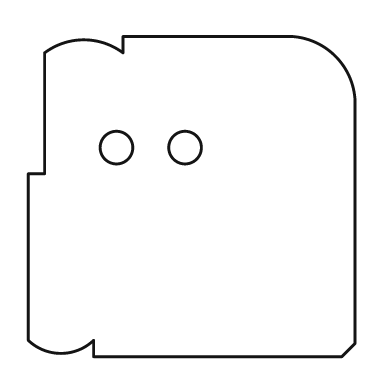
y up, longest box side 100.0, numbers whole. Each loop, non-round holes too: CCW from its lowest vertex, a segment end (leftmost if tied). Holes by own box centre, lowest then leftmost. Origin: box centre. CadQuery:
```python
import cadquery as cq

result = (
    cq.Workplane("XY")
    .moveTo(-30.0, -49.0)
    .lineTo(46.0, -49.0)
    .lineTo(50.0, -45.0)
    .lineTo(50.0, 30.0)
    .threePointArc((44.0, 43.0), (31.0, 49.0))
    .lineTo(-21.0, 49.0)
    .lineTo(-21.0, 44.0)
    .threePointArc((-33.0, 48.0), (-45.0, 44.0))
    .lineTo(-45.0, 7.0)
    .lineTo(-50.0, 7.0)
    .lineTo(-50.0, -44.0)
    .threePointArc((-40.0, -48.0), (-30.0, -44.0))
    .close()
    .moveTo(-23.0, 15.0)
    .circle(5.0)
    .moveTo(-2.0, 15.0)
    .circle(5.0)
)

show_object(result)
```